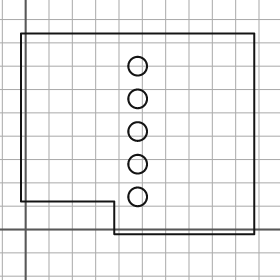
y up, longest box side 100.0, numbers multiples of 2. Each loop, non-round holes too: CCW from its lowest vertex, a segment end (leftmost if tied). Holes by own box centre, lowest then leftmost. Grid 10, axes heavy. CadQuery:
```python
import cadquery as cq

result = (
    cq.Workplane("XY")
    .moveTo(38.0, -2.0)
    .lineTo(98.0, -2.0)
    .lineTo(98.0, 84.0)
    .lineTo(-2.0, 84.0)
    .lineTo(-2.0, 12.0)
    .lineTo(38.0, 12.0)
    .close()
    .moveTo(48.0, 14.0)
    .circle(4.0)
    .moveTo(48.0, 28.0)
    .circle(4.0)
    .moveTo(48.0, 42.0)
    .circle(4.0)
    .moveTo(48.0, 56.0)
    .circle(4.0)
    .moveTo(48.0, 70.0)
    .circle(4.0)
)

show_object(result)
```